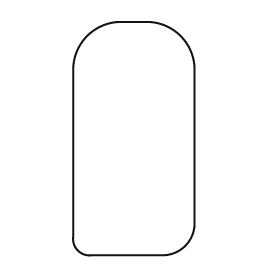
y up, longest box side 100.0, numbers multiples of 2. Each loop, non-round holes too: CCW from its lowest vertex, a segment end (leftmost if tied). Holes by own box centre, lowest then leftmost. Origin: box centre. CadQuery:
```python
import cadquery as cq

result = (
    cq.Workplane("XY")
    .moveTo(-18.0, -50.0)
    .lineTo(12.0, -50.0)
    .threePointArc((22.0, -46.0), (26.0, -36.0))
    .lineTo(26.0, 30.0)
    .threePointArc((20.0, 44.0), (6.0, 50.0))
    .lineTo(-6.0, 50.0)
    .threePointArc((-20.0, 44.0), (-26.0, 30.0))
    .lineTo(-26.0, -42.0)
    .threePointArc((-24.0, -48.0), (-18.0, -50.0))
    .close()
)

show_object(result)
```